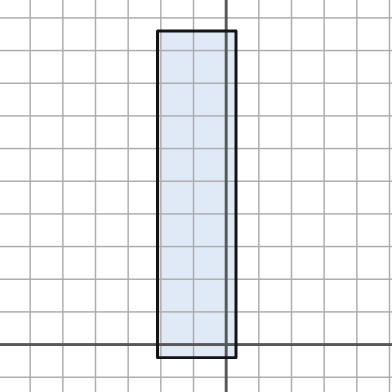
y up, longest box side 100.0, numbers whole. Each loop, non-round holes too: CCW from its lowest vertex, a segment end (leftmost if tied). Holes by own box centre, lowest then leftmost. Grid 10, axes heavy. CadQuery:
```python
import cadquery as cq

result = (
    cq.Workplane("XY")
    .moveTo(-21.0, -4.0)
    .lineTo(3.0, -4.0)
    .lineTo(3.0, 96.0)
    .lineTo(-21.0, 96.0)
    .close()
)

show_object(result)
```